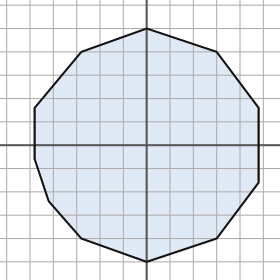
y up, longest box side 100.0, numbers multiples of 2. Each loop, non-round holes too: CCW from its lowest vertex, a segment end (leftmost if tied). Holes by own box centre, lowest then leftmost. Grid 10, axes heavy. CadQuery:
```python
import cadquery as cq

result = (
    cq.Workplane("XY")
    .moveTo(0.0, -50.0)
    .lineTo(30.0, -40.0)
    .lineTo(48.0, -16.0)
    .lineTo(48.0, 16.0)
    .lineTo(30.0, 40.0)
    .lineTo(0.0, 50.0)
    .lineTo(-28.0, 40.0)
    .lineTo(-48.0, 16.0)
    .lineTo(-48.0, -6.0)
    .lineTo(-42.0, -24.0)
    .lineTo(-28.0, -40.0)
    .close()
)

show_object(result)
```